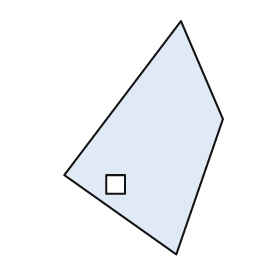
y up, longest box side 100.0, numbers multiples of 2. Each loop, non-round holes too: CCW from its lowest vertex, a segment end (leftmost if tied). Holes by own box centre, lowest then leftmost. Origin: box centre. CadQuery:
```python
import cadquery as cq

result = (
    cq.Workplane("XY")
    .moveTo(14.0, -50.0)
    .lineTo(34.0, 8.0)
    .lineTo(16.0, 50.0)
    .lineTo(-34.0, -16.0)
    .close()
    .moveTo(-16.0, -24.0)
    .lineTo(-8.0, -24.0)
    .lineTo(-8.0, -16.0)
    .lineTo(-16.0, -16.0)
    .close()
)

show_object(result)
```